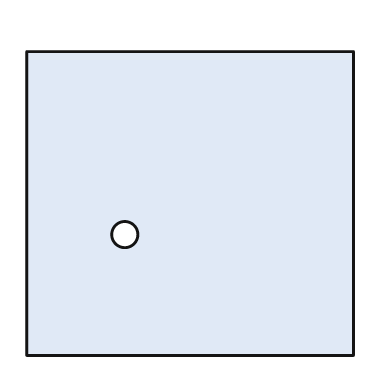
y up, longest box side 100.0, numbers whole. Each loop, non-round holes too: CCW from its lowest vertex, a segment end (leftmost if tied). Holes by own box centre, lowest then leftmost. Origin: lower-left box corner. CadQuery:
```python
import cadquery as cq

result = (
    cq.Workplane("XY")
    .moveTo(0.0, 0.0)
    .lineTo(100.0, 0.0)
    .lineTo(100.0, 93.0)
    .lineTo(0.0, 93.0)
    .close()
    .moveTo(30.0, 37.0)
    .circle(4.0)
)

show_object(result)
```